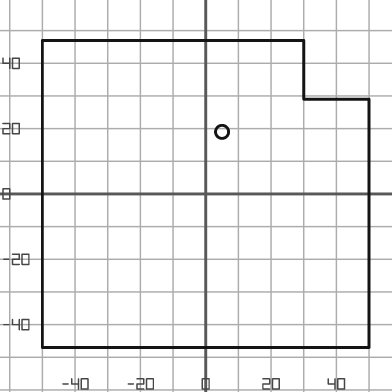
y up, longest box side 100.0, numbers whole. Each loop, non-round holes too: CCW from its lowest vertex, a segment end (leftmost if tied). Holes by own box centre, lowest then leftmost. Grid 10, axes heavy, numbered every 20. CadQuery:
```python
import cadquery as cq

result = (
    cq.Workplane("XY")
    .moveTo(-50.0, -47.0)
    .lineTo(50.0, -47.0)
    .lineTo(50.0, 29.0)
    .lineTo(30.0, 29.0)
    .lineTo(30.0, 47.0)
    .lineTo(-50.0, 47.0)
    .close()
    .moveTo(5.0, 19.0)
    .circle(2.0)
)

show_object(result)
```